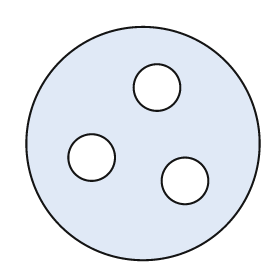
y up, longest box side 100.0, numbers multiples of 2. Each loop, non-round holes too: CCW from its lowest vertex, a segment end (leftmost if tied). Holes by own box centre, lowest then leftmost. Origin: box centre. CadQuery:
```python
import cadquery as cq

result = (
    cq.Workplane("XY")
    .moveTo(0.0, 0.0)
    .circle(50.0)
    .moveTo(18.0, -16.0)
    .circle(10.0)
    .moveTo(-22.0, -6.0)
    .circle(10.0)
    .moveTo(6.0, 24.0)
    .circle(10.0)
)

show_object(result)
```